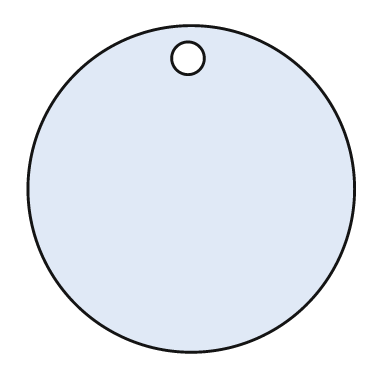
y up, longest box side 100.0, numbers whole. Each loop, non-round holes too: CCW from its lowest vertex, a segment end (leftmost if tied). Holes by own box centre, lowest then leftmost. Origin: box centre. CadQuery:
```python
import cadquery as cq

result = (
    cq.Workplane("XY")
    .moveTo(0.0, 0.0)
    .circle(50.0)
    .moveTo(-1.0, 40.0)
    .circle(5.0)
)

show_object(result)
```